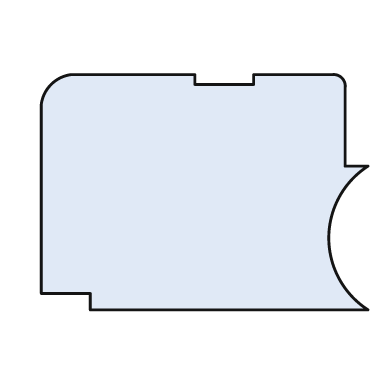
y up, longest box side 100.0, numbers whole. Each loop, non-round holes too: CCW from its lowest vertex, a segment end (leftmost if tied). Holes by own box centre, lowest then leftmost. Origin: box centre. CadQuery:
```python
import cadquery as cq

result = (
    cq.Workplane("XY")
    .moveTo(-35.0, -36.0)
    .lineTo(50.0, -36.0)
    .threePointArc((38.0, -14.0), (50.0, 8.0))
    .lineTo(43.0, 8.0)
    .lineTo(43.0, 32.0)
    .threePointArc((42.0, 35.0), (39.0, 36.0))
    .lineTo(15.0, 36.0)
    .lineTo(15.0, 33.0)
    .lineTo(-3.0, 33.0)
    .lineTo(-3.0, 36.0)
    .lineTo(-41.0, 36.0)
    .threePointArc((-47.0, 33.0), (-50.0, 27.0))
    .lineTo(-50.0, -31.0)
    .lineTo(-35.0, -31.0)
    .close()
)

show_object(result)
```